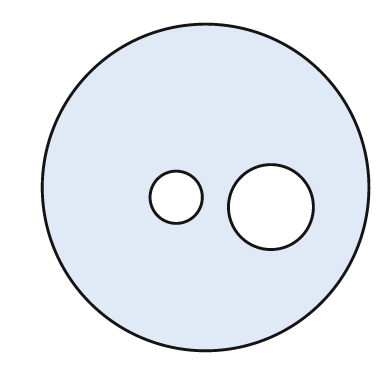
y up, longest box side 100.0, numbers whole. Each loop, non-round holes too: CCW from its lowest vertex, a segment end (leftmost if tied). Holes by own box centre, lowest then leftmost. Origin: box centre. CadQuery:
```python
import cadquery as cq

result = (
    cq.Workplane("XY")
    .moveTo(0.0, 0.0)
    .circle(50.0)
    .moveTo(20.0, -6.0)
    .circle(13.0)
    .moveTo(-9.0, -3.0)
    .circle(8.0)
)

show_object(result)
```